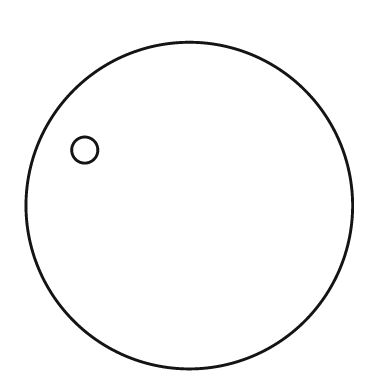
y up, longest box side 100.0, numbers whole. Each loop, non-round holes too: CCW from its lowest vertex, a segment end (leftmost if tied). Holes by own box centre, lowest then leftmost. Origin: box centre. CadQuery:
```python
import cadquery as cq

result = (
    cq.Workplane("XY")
    .moveTo(0.0, 0.0)
    .circle(50.0)
    .moveTo(-32.0, 17.0)
    .circle(4.0)
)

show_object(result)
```